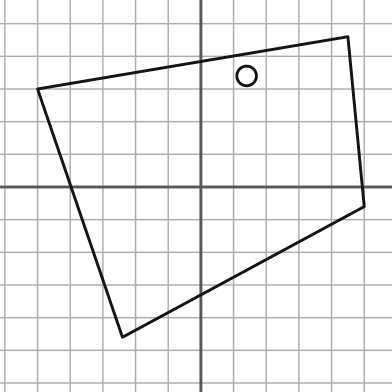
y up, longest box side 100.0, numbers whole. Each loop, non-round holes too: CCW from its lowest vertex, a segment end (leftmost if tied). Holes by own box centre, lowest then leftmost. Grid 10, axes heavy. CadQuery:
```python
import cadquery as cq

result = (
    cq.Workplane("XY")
    .moveTo(-24.0, -46.0)
    .lineTo(50.0, -6.0)
    .lineTo(45.0, 46.0)
    .lineTo(-50.0, 30.0)
    .close()
    .moveTo(14.0, 34.0)
    .circle(3.0)
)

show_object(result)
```